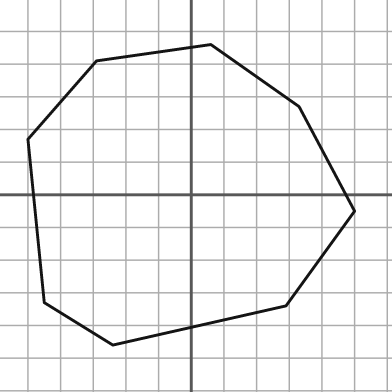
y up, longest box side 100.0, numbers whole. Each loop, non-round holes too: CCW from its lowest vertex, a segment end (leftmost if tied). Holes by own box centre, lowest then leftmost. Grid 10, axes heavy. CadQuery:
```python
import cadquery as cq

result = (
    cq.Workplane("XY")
    .moveTo(-24.0, -46.0)
    .lineTo(29.0, -34.0)
    .lineTo(50.0, -5.0)
    .lineTo(33.0, 27.0)
    .lineTo(6.0, 46.0)
    .lineTo(-29.0, 41.0)
    .lineTo(-50.0, 17.0)
    .lineTo(-45.0, -33.0)
    .close()
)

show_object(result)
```